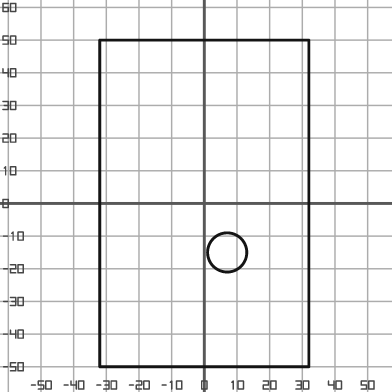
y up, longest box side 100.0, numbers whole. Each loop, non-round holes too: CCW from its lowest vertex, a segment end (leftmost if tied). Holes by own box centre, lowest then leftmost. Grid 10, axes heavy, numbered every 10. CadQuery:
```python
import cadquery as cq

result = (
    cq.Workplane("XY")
    .moveTo(-32.0, -50.0)
    .lineTo(32.0, -50.0)
    .lineTo(32.0, 50.0)
    .lineTo(-32.0, 50.0)
    .close()
    .moveTo(7.0, -15.0)
    .circle(6.0)
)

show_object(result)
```